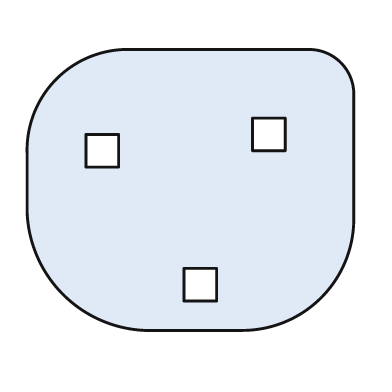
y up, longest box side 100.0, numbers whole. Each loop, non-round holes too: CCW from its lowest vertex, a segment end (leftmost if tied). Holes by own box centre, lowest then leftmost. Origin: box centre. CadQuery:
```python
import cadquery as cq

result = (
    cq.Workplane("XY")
    .moveTo(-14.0, -43.0)
    .lineTo(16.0, -43.0)
    .threePointArc((40.0, -33.0), (50.0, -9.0))
    .lineTo(50.0, 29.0)
    .threePointArc((46.0, 39.0), (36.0, 43.0))
    .lineTo(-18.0, 43.0)
    .threePointArc((-41.0, 34.0), (-50.0, 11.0))
    .lineTo(-50.0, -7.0)
    .threePointArc((-39.0, -32.0), (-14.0, -43.0))
    .close()
    .moveTo(-2.0, -34.0)
    .lineTo(8.0, -34.0)
    .lineTo(8.0, -24.0)
    .lineTo(-2.0, -24.0)
    .close()
    .moveTo(-32.0, 7.0)
    .lineTo(-22.0, 7.0)
    .lineTo(-22.0, 17.0)
    .lineTo(-32.0, 17.0)
    .close()
    .moveTo(19.0, 12.0)
    .lineTo(29.0, 12.0)
    .lineTo(29.0, 22.0)
    .lineTo(19.0, 22.0)
    .close()
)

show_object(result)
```